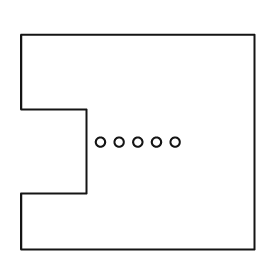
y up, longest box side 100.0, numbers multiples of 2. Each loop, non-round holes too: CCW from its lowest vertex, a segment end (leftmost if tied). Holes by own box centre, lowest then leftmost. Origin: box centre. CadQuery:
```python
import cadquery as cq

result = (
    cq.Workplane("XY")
    .moveTo(-50.0, -46.0)
    .lineTo(50.0, -46.0)
    .lineTo(50.0, 46.0)
    .lineTo(-50.0, 46.0)
    .lineTo(-50.0, 14.0)
    .lineTo(-22.0, 14.0)
    .lineTo(-22.0, -22.0)
    .lineTo(-50.0, -22.0)
    .close()
    .moveTo(-16.0, 0.0)
    .circle(2.0)
    .moveTo(-8.0, 0.0)
    .circle(2.0)
    .moveTo(0.0, 0.0)
    .circle(2.0)
    .moveTo(8.0, 0.0)
    .circle(2.0)
    .moveTo(16.0, 0.0)
    .circle(2.0)
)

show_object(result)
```